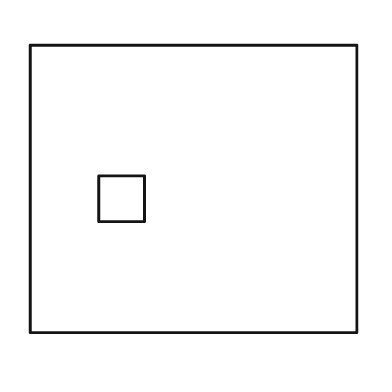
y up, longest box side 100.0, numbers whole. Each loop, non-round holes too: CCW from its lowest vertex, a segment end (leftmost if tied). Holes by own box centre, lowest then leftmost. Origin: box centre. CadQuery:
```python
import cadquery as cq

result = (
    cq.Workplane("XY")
    .moveTo(-50.0, -44.0)
    .lineTo(50.0, -44.0)
    .lineTo(50.0, 44.0)
    .lineTo(-50.0, 44.0)
    .close()
    .moveTo(-29.0, -10.0)
    .lineTo(-15.0, -10.0)
    .lineTo(-15.0, 4.0)
    .lineTo(-29.0, 4.0)
    .close()
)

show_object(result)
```